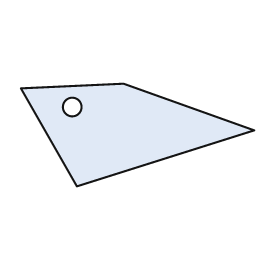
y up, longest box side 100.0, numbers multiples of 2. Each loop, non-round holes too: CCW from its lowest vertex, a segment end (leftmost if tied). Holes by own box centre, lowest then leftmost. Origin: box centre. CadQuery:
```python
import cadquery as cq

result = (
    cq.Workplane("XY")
    .moveTo(-26.0, -22.0)
    .lineTo(50.0, 2.0)
    .lineTo(-6.0, 22.0)
    .lineTo(-50.0, 20.0)
    .close()
    .moveTo(-28.0, 12.0)
    .circle(4.0)
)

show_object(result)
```